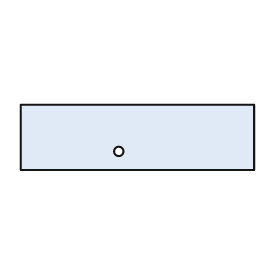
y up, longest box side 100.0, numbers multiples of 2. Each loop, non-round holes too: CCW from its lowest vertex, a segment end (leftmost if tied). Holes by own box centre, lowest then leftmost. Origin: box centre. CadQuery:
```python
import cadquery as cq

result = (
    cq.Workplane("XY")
    .moveTo(-50.0, -14.0)
    .lineTo(50.0, -14.0)
    .lineTo(50.0, 14.0)
    .lineTo(-50.0, 14.0)
    .close()
    .moveTo(-8.0, -6.0)
    .circle(2.0)
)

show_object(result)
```